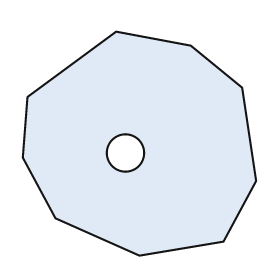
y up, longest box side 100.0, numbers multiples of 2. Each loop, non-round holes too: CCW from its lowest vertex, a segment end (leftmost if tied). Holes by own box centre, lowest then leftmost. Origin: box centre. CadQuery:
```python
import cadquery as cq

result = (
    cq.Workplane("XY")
    .moveTo(0.0, -48.0)
    .lineTo(36.0, -42.0)
    .lineTo(50.0, -16.0)
    .lineTo(44.0, 24.0)
    .lineTo(22.0, 42.0)
    .lineTo(-10.0, 48.0)
    .lineTo(-48.0, 20.0)
    .lineTo(-50.0, -6.0)
    .lineTo(-36.0, -32.0)
    .close()
    .moveTo(-6.0, -4.0)
    .circle(8.0)
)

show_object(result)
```